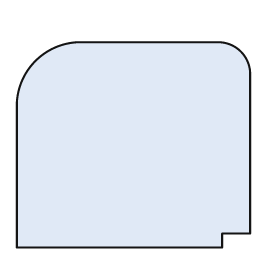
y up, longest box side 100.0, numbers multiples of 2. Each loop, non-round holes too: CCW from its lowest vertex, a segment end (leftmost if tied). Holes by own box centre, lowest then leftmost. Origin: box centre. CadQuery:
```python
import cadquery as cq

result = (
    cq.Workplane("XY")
    .moveTo(-50.0, -44.0)
    .lineTo(38.0, -44.0)
    .lineTo(38.0, -38.0)
    .lineTo(50.0, -38.0)
    .lineTo(50.0, 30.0)
    .threePointArc((46.0, 40.0), (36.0, 44.0))
    .lineTo(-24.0, 44.0)
    .threePointArc((-42.0, 36.0), (-50.0, 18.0))
    .close()
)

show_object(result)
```